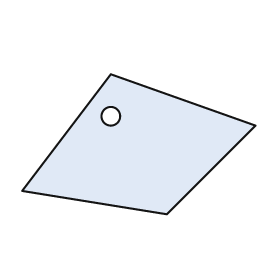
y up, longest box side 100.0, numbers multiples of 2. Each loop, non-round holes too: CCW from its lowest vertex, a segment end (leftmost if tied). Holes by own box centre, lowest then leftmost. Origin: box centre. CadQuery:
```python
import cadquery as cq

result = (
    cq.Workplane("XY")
    .moveTo(12.0, -30.0)
    .lineTo(50.0, 8.0)
    .lineTo(-12.0, 30.0)
    .lineTo(-50.0, -20.0)
    .close()
    .moveTo(-12.0, 12.0)
    .circle(4.0)
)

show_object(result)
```